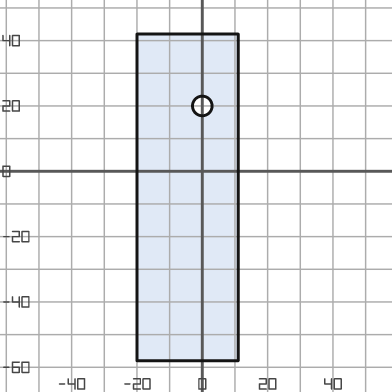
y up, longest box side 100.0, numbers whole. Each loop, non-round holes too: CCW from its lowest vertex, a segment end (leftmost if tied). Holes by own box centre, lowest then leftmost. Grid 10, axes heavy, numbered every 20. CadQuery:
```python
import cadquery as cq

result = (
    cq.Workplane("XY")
    .moveTo(-20.0, -58.0)
    .lineTo(11.0, -58.0)
    .lineTo(11.0, 42.0)
    .lineTo(-20.0, 42.0)
    .close()
    .moveTo(0.0, 20.0)
    .circle(3.0)
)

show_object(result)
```